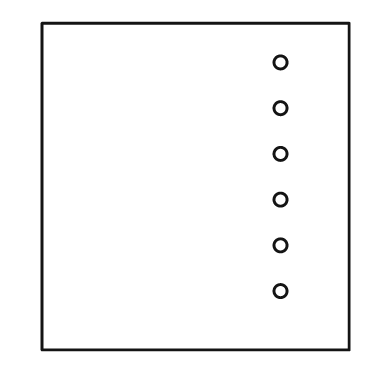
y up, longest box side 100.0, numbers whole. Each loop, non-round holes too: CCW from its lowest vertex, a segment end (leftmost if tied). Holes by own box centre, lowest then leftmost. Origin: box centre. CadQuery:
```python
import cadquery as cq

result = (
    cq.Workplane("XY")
    .moveTo(-47.0, -50.0)
    .lineTo(47.0, -50.0)
    .lineTo(47.0, 50.0)
    .lineTo(-47.0, 50.0)
    .close()
    .moveTo(26.0, -32.0)
    .circle(2.0)
    .moveTo(26.0, -18.0)
    .circle(2.0)
    .moveTo(26.0, -4.0)
    .circle(2.0)
    .moveTo(26.0, 10.0)
    .circle(2.0)
    .moveTo(26.0, 24.0)
    .circle(2.0)
    .moveTo(26.0, 38.0)
    .circle(2.0)
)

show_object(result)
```